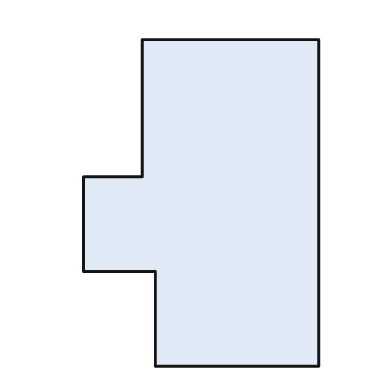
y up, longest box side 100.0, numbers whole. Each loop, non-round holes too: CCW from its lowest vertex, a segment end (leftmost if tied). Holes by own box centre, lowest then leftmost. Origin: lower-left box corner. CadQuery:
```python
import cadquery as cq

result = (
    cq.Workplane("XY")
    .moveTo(22.0, 0.0)
    .lineTo(72.0, 0.0)
    .lineTo(72.0, 100.0)
    .lineTo(18.0, 100.0)
    .lineTo(18.0, 58.0)
    .lineTo(0.0, 58.0)
    .lineTo(0.0, 29.0)
    .lineTo(22.0, 29.0)
    .close()
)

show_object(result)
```